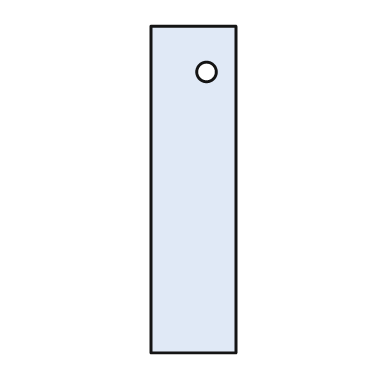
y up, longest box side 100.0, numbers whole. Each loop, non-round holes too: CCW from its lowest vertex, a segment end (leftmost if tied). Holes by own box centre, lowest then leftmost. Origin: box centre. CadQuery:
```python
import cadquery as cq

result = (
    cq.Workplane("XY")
    .moveTo(-13.0, -50.0)
    .lineTo(13.0, -50.0)
    .lineTo(13.0, 50.0)
    .lineTo(-13.0, 50.0)
    .close()
    .moveTo(4.0, 36.0)
    .circle(3.0)
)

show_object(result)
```